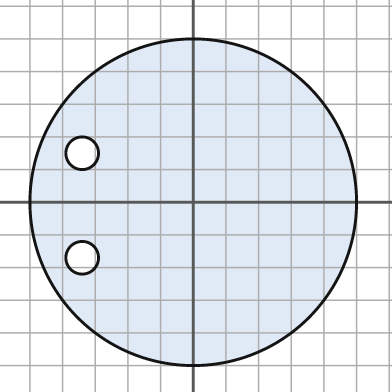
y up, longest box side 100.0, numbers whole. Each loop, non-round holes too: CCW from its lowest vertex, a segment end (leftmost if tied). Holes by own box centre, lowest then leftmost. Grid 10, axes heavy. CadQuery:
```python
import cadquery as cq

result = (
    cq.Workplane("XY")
    .moveTo(0.0, 0.0)
    .circle(50.0)
    .moveTo(-34.0, -17.0)
    .circle(5.0)
    .moveTo(-34.0, 15.0)
    .circle(5.0)
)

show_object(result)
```